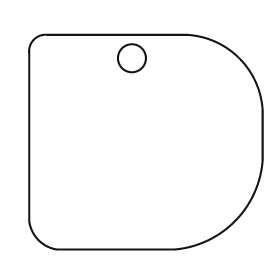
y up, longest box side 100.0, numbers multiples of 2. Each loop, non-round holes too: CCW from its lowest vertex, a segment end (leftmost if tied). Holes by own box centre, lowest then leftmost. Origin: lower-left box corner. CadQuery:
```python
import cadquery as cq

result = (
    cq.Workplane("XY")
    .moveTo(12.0, 0.0)
    .lineTo(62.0, 0.0)
    .threePointArc((88.0, 12.0), (100.0, 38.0))
    .lineTo(100.0, 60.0)
    .threePointArc((90.0, 82.0), (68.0, 92.0))
    .lineTo(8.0, 92.0)
    .threePointArc((2.0, 90.0), (0.0, 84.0))
    .lineTo(0.0, 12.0)
    .threePointArc((4.0, 4.0), (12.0, 0.0))
    .close()
    .moveTo(44.0, 82.0)
    .circle(6.0)
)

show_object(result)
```